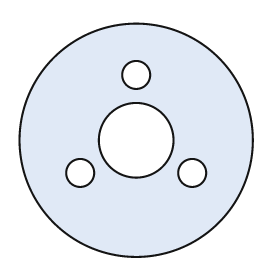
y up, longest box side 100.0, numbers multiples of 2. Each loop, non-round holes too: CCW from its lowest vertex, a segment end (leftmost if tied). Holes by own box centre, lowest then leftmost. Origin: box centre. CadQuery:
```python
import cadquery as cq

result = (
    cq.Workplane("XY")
    .moveTo(0.0, 0.0)
    .circle(50.0)
    .moveTo(-24.0, -14.0)
    .circle(6.0)
    .moveTo(24.0, -14.0)
    .circle(6.0)
    .moveTo(0.0, 0.0)
    .circle(16.0)
    .moveTo(0.0, 28.0)
    .circle(6.0)
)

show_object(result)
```